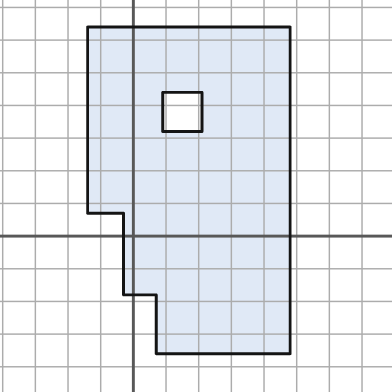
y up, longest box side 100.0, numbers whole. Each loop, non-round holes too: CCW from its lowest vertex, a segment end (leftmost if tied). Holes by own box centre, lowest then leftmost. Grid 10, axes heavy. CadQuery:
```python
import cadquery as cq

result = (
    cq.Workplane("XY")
    .moveTo(7.0, -36.0)
    .lineTo(48.0, -36.0)
    .lineTo(48.0, 64.0)
    .lineTo(-14.0, 64.0)
    .lineTo(-14.0, 7.0)
    .lineTo(-3.0, 7.0)
    .lineTo(-3.0, -18.0)
    .lineTo(7.0, -18.0)
    .close()
    .moveTo(9.0, 32.0)
    .lineTo(21.0, 32.0)
    .lineTo(21.0, 44.0)
    .lineTo(9.0, 44.0)
    .close()
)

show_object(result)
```